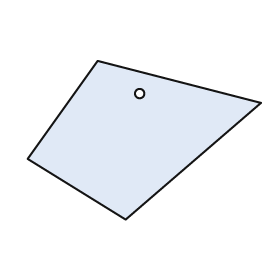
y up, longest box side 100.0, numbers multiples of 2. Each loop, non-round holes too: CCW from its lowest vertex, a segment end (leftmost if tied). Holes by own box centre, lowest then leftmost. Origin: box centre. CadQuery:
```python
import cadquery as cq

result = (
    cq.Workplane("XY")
    .moveTo(-8.0, -34.0)
    .lineTo(50.0, 16.0)
    .lineTo(-20.0, 34.0)
    .lineTo(-50.0, -8.0)
    .close()
    .moveTo(-2.0, 20.0)
    .circle(2.0)
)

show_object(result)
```